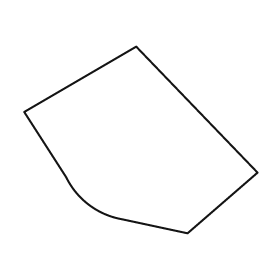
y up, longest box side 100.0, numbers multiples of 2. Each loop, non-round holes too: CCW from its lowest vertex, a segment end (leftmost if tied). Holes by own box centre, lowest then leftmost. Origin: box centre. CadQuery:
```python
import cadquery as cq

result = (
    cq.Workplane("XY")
    .moveTo(20.0, -40.0)
    .lineTo(50.0, -14.0)
    .lineTo(-2.0, 40.0)
    .lineTo(-50.0, 12.0)
    .lineTo(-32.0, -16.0)
    .threePointArc((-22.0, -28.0), (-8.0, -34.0))
    .close()
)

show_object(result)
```